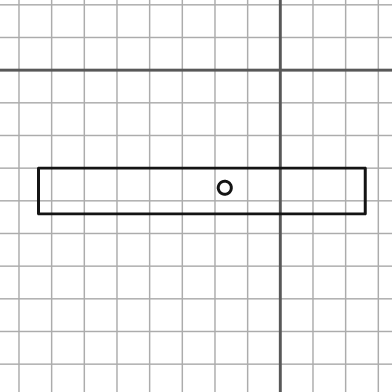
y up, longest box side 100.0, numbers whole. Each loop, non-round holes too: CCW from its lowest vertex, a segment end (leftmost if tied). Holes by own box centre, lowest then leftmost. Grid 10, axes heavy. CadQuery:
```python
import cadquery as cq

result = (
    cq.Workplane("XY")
    .moveTo(-74.0, -44.0)
    .lineTo(26.0, -44.0)
    .lineTo(26.0, -30.0)
    .lineTo(-74.0, -30.0)
    .close()
    .moveTo(-17.0, -36.0)
    .circle(2.0)
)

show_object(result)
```